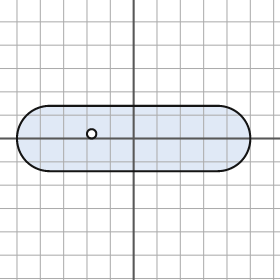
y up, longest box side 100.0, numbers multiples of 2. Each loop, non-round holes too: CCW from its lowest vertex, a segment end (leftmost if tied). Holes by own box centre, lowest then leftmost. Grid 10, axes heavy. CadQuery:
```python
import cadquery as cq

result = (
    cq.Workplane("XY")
    .moveTo(-36.0, -14.0)
    .lineTo(36.0, -14.0)
    .threePointArc((50.0, 0.0), (36.0, 14.0))
    .lineTo(-36.0, 14.0)
    .threePointArc((-50.0, 0.0), (-36.0, -14.0))
    .close()
    .moveTo(-18.0, 2.0)
    .circle(2.0)
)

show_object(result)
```